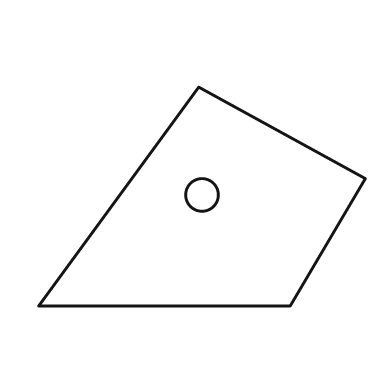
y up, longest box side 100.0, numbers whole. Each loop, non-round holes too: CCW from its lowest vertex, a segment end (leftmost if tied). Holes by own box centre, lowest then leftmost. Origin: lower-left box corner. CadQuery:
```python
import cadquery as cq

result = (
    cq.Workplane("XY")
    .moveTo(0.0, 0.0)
    .lineTo(77.0, 0.0)
    .lineTo(100.0, 39.0)
    .lineTo(49.0, 67.0)
    .close()
    .moveTo(50.0, 34.0)
    .circle(5.0)
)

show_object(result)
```